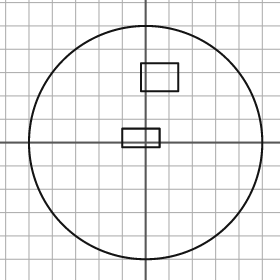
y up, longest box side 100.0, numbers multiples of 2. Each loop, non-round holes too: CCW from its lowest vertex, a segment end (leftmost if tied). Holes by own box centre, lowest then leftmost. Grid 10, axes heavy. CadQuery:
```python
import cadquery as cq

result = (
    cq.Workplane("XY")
    .moveTo(0.0, 0.0)
    .circle(50.0)
    .moveTo(-10.0, -2.0)
    .lineTo(6.0, -2.0)
    .lineTo(6.0, 6.0)
    .lineTo(-10.0, 6.0)
    .close()
    .moveTo(-2.0, 22.0)
    .lineTo(14.0, 22.0)
    .lineTo(14.0, 34.0)
    .lineTo(-2.0, 34.0)
    .close()
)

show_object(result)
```